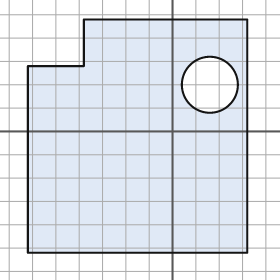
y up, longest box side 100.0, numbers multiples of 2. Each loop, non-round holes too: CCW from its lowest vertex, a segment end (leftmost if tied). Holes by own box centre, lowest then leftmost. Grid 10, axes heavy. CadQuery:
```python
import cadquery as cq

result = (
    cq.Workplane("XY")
    .moveTo(-62.0, -52.0)
    .lineTo(32.0, -52.0)
    .lineTo(32.0, 48.0)
    .lineTo(-38.0, 48.0)
    .lineTo(-38.0, 28.0)
    .lineTo(-62.0, 28.0)
    .close()
    .moveTo(16.0, 20.0)
    .circle(12.0)
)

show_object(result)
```